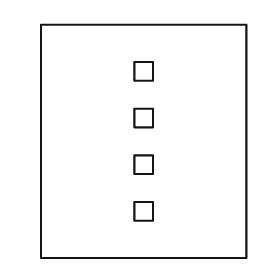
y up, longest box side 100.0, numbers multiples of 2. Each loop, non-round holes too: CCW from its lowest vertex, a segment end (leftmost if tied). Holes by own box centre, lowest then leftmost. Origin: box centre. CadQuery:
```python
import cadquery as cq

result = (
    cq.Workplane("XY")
    .moveTo(-44.0, -50.0)
    .lineTo(44.0, -50.0)
    .lineTo(44.0, 50.0)
    .lineTo(-44.0, 50.0)
    .close()
    .moveTo(-4.0, -34.0)
    .lineTo(4.0, -34.0)
    .lineTo(4.0, -26.0)
    .lineTo(-4.0, -26.0)
    .close()
    .moveTo(-4.0, -14.0)
    .lineTo(4.0, -14.0)
    .lineTo(4.0, -6.0)
    .lineTo(-4.0, -6.0)
    .close()
    .moveTo(-4.0, 6.0)
    .lineTo(4.0, 6.0)
    .lineTo(4.0, 14.0)
    .lineTo(-4.0, 14.0)
    .close()
    .moveTo(-4.0, 26.0)
    .lineTo(4.0, 26.0)
    .lineTo(4.0, 34.0)
    .lineTo(-4.0, 34.0)
    .close()
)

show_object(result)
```